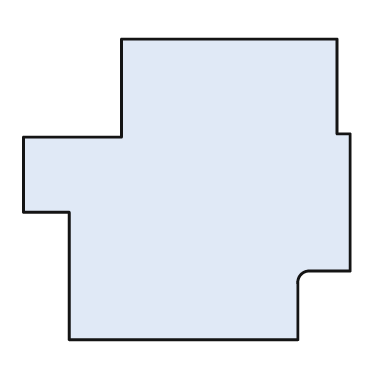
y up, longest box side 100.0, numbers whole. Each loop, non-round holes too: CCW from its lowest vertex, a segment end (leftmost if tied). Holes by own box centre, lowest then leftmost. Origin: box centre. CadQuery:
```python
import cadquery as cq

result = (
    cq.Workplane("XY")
    .moveTo(-36.0, -46.0)
    .lineTo(34.0, -46.0)
    .lineTo(34.0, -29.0)
    .threePointArc((35.0, -26.0), (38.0, -25.0))
    .lineTo(50.0, -25.0)
    .lineTo(50.0, 17.0)
    .lineTo(46.0, 17.0)
    .lineTo(46.0, 46.0)
    .lineTo(-20.0, 46.0)
    .lineTo(-20.0, 16.0)
    .lineTo(-50.0, 16.0)
    .lineTo(-50.0, -7.0)
    .lineTo(-36.0, -7.0)
    .close()
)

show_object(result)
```